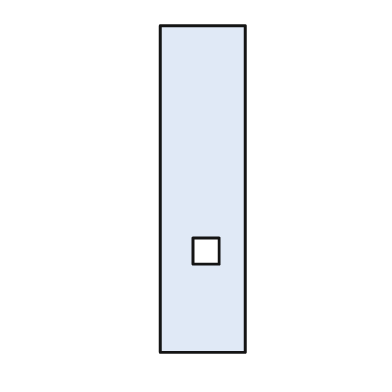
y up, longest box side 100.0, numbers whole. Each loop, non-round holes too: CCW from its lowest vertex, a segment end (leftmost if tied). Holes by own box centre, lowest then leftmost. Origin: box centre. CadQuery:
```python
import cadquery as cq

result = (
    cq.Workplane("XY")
    .moveTo(-13.0, -50.0)
    .lineTo(13.0, -50.0)
    .lineTo(13.0, 50.0)
    .lineTo(-13.0, 50.0)
    .close()
    .moveTo(-3.0, -23.0)
    .lineTo(5.0, -23.0)
    .lineTo(5.0, -15.0)
    .lineTo(-3.0, -15.0)
    .close()
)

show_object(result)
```